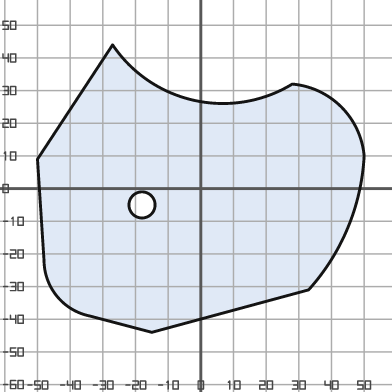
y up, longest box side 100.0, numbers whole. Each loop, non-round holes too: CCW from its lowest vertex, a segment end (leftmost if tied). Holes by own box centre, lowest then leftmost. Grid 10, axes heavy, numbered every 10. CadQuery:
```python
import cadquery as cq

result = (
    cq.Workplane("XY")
    .moveTo(-15.0, -44.0)
    .lineTo(33.0, -31.0)
    .threePointArc((45.0, -12.0), (50.0, 10.0))
    .threePointArc((43.0, 25.0), (28.0, 32.0))
    .threePointArc((-2.0, 27.0), (-27.0, 44.0))
    .lineTo(-50.0, 9.0)
    .lineTo(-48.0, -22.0)
    .threePointArc((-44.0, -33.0), (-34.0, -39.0))
    .close()
    .moveTo(-18.0, -5.0)
    .circle(4.0)
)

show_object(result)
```